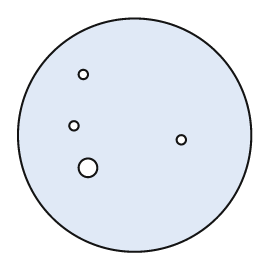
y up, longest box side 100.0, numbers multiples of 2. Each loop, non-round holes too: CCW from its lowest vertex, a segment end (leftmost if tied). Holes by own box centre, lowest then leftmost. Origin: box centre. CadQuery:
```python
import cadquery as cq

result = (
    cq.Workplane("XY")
    .moveTo(0.0, 0.0)
    .circle(50.0)
    .moveTo(-20.0, -14.0)
    .circle(4.0)
    .moveTo(20.0, -2.0)
    .circle(2.0)
    .moveTo(-26.0, 4.0)
    .circle(2.0)
    .moveTo(-22.0, 26.0)
    .circle(2.0)
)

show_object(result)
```